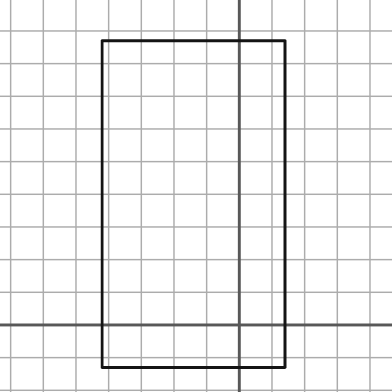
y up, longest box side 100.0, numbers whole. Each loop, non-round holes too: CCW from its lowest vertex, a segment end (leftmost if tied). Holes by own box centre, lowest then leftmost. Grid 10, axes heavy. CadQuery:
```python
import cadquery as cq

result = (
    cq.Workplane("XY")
    .moveTo(-42.0, -13.0)
    .lineTo(14.0, -13.0)
    .lineTo(14.0, 87.0)
    .lineTo(-42.0, 87.0)
    .close()
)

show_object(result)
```